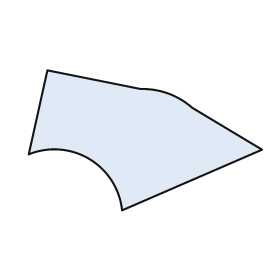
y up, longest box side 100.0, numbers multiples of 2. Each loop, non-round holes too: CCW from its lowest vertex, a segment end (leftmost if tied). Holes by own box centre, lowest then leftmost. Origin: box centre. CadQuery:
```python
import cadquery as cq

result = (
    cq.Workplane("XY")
    .moveTo(-10.0, -30.0)
    .lineTo(50.0, -4.0)
    .lineTo(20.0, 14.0)
    .threePointArc((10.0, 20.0), (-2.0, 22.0))
    .lineTo(-42.0, 30.0)
    .lineTo(-50.0, -6.0)
    .threePointArc((-24.0, -8.0), (-10.0, -30.0))
    .close()
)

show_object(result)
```